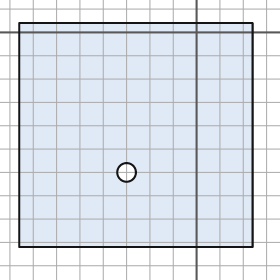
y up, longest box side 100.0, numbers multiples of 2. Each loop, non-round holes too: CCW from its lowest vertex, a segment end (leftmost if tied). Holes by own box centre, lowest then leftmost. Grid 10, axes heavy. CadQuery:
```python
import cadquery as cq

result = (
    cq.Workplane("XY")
    .moveTo(-76.0, -92.0)
    .lineTo(24.0, -92.0)
    .lineTo(24.0, 4.0)
    .lineTo(-76.0, 4.0)
    .close()
    .moveTo(-30.0, -60.0)
    .circle(4.0)
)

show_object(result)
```